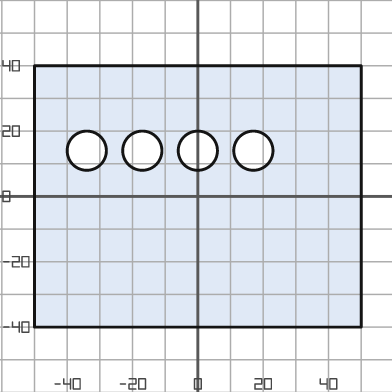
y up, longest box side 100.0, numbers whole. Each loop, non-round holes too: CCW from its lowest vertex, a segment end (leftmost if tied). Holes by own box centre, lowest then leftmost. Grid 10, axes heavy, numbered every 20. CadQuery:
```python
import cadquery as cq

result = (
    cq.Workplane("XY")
    .moveTo(-50.0, -40.0)
    .lineTo(50.0, -40.0)
    .lineTo(50.0, 40.0)
    .lineTo(-50.0, 40.0)
    .close()
    .moveTo(-34.0, 14.0)
    .circle(6.0)
    .moveTo(-17.0, 14.0)
    .circle(6.0)
    .moveTo(0.0, 14.0)
    .circle(6.0)
    .moveTo(17.0, 14.0)
    .circle(6.0)
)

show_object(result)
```